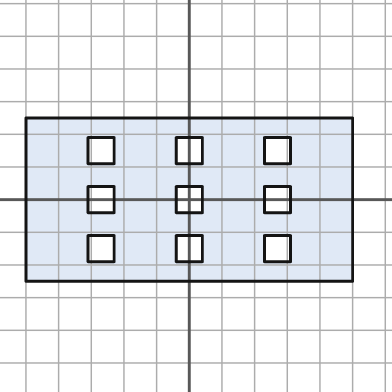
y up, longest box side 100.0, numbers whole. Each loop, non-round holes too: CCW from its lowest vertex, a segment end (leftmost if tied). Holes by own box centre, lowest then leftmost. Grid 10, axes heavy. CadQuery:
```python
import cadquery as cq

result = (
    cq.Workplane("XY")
    .moveTo(-50.0, -25.0)
    .lineTo(50.0, -25.0)
    .lineTo(50.0, 25.0)
    .lineTo(-50.0, 25.0)
    .close()
    .moveTo(-31.0, -19.0)
    .lineTo(-23.0, -19.0)
    .lineTo(-23.0, -11.0)
    .lineTo(-31.0, -11.0)
    .close()
    .moveTo(-4.0, -19.0)
    .lineTo(4.0, -19.0)
    .lineTo(4.0, -11.0)
    .lineTo(-4.0, -11.0)
    .close()
    .moveTo(23.0, -19.0)
    .lineTo(31.0, -19.0)
    .lineTo(31.0, -11.0)
    .lineTo(23.0, -11.0)
    .close()
    .moveTo(-31.0, -4.0)
    .lineTo(-23.0, -4.0)
    .lineTo(-23.0, 4.0)
    .lineTo(-31.0, 4.0)
    .close()
    .moveTo(-4.0, -4.0)
    .lineTo(4.0, -4.0)
    .lineTo(4.0, 4.0)
    .lineTo(-4.0, 4.0)
    .close()
    .moveTo(23.0, -4.0)
    .lineTo(31.0, -4.0)
    .lineTo(31.0, 4.0)
    .lineTo(23.0, 4.0)
    .close()
    .moveTo(-31.0, 11.0)
    .lineTo(-23.0, 11.0)
    .lineTo(-23.0, 19.0)
    .lineTo(-31.0, 19.0)
    .close()
    .moveTo(-4.0, 11.0)
    .lineTo(4.0, 11.0)
    .lineTo(4.0, 19.0)
    .lineTo(-4.0, 19.0)
    .close()
    .moveTo(23.0, 11.0)
    .lineTo(31.0, 11.0)
    .lineTo(31.0, 19.0)
    .lineTo(23.0, 19.0)
    .close()
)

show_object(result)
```